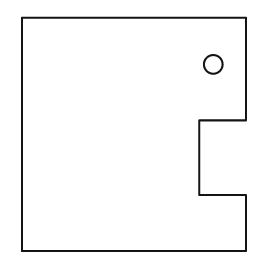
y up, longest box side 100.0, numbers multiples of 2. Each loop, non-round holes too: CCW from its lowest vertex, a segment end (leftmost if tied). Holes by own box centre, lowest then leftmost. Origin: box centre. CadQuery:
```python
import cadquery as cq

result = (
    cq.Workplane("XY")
    .moveTo(-48.0, -50.0)
    .lineTo(48.0, -50.0)
    .lineTo(48.0, -26.0)
    .lineTo(28.0, -26.0)
    .lineTo(28.0, 6.0)
    .lineTo(48.0, 6.0)
    .lineTo(48.0, 50.0)
    .lineTo(-48.0, 50.0)
    .close()
    .moveTo(34.0, 30.0)
    .circle(4.0)
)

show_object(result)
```